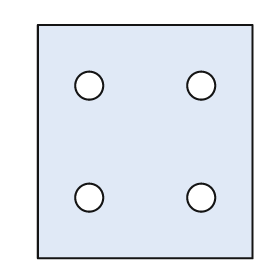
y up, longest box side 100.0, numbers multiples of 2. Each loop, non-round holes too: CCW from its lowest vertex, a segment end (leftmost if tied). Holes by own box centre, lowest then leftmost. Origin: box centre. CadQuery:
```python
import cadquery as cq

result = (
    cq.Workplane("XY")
    .moveTo(-46.0, -50.0)
    .lineTo(46.0, -50.0)
    .lineTo(46.0, 50.0)
    .lineTo(-46.0, 50.0)
    .close()
    .moveTo(-24.0, -24.0)
    .circle(6.0)
    .moveTo(24.0, -24.0)
    .circle(6.0)
    .moveTo(-24.0, 24.0)
    .circle(6.0)
    .moveTo(24.0, 24.0)
    .circle(6.0)
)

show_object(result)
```